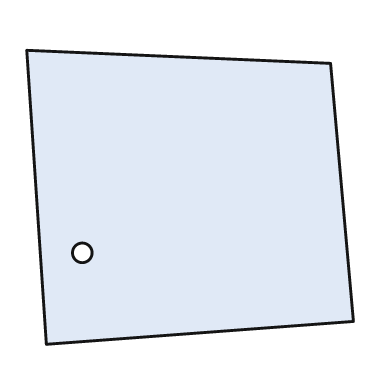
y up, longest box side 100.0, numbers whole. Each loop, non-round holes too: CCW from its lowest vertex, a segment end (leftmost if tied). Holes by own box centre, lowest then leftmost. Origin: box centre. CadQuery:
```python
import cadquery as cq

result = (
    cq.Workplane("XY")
    .moveTo(-44.0, -45.0)
    .lineTo(50.0, -38.0)
    .lineTo(43.0, 41.0)
    .lineTo(-50.0, 45.0)
    .close()
    .moveTo(-33.0, -17.0)
    .circle(3.0)
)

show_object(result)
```